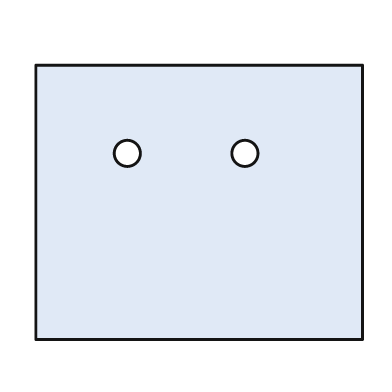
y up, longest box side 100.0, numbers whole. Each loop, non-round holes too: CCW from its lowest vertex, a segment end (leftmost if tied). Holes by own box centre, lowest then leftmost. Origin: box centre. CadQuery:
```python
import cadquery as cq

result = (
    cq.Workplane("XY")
    .moveTo(-50.0, -42.0)
    .lineTo(50.0, -42.0)
    .lineTo(50.0, 42.0)
    .lineTo(-50.0, 42.0)
    .close()
    .moveTo(-22.0, 15.0)
    .circle(4.0)
    .moveTo(14.0, 15.0)
    .circle(4.0)
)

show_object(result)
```